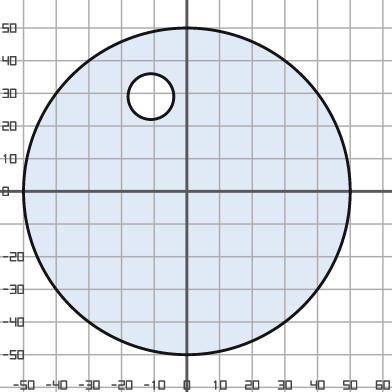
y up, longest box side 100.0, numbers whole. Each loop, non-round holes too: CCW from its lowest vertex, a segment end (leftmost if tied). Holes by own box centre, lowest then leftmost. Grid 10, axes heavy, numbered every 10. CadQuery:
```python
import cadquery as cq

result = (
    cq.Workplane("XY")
    .moveTo(0.0, 0.0)
    .circle(50.0)
    .moveTo(-11.0, 29.0)
    .circle(7.0)
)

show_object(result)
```